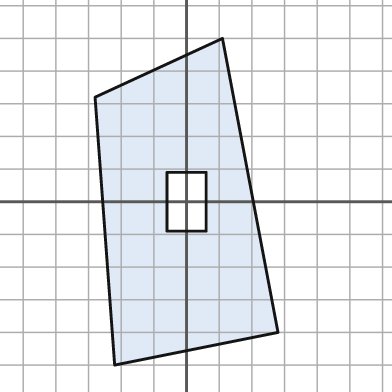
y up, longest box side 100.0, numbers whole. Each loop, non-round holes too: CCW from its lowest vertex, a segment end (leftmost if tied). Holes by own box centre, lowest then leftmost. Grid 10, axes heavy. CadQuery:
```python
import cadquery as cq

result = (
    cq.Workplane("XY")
    .moveTo(-22.0, -50.0)
    .lineTo(28.0, -40.0)
    .lineTo(11.0, 50.0)
    .lineTo(-28.0, 32.0)
    .close()
    .moveTo(-6.0, -9.0)
    .lineTo(6.0, -9.0)
    .lineTo(6.0, 9.0)
    .lineTo(-6.0, 9.0)
    .close()
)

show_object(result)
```